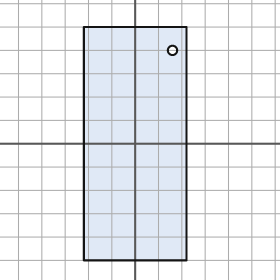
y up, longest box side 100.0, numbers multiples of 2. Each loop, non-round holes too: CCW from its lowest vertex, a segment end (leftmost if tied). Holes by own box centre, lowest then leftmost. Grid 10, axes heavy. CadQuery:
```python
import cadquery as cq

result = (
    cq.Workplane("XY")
    .moveTo(-22.0, -50.0)
    .lineTo(22.0, -50.0)
    .lineTo(22.0, 50.0)
    .lineTo(-22.0, 50.0)
    .close()
    .moveTo(16.0, 40.0)
    .circle(2.0)
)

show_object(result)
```